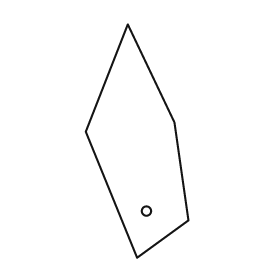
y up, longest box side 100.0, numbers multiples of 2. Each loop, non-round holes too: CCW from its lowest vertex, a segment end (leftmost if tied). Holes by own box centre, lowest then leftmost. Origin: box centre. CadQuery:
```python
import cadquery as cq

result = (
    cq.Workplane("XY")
    .moveTo(0.0, -50.0)
    .lineTo(22.0, -34.0)
    .lineTo(16.0, 8.0)
    .lineTo(-4.0, 50.0)
    .lineTo(-22.0, 4.0)
    .close()
    .moveTo(4.0, -30.0)
    .circle(2.0)
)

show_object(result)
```